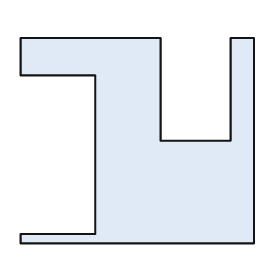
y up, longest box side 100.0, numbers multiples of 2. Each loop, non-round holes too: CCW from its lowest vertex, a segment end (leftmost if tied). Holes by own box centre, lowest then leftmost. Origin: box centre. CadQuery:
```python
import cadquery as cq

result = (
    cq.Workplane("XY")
    .moveTo(-50.0, -44.0)
    .lineTo(50.0, -44.0)
    .lineTo(50.0, 44.0)
    .lineTo(40.0, 44.0)
    .lineTo(40.0, 0.0)
    .lineTo(10.0, 0.0)
    .lineTo(10.0, 44.0)
    .lineTo(-50.0, 44.0)
    .lineTo(-50.0, 28.0)
    .lineTo(-18.0, 28.0)
    .lineTo(-18.0, -40.0)
    .lineTo(-50.0, -40.0)
    .close()
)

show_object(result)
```